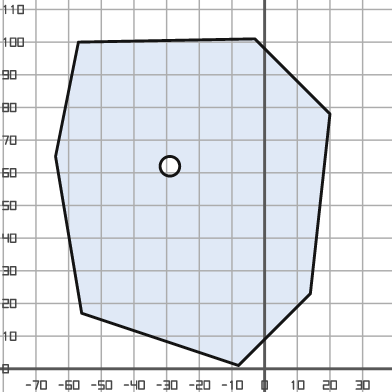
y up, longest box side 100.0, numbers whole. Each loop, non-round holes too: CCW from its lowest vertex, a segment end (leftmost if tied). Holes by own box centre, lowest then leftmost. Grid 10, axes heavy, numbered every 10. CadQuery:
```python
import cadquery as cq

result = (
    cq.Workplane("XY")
    .moveTo(-8.0, 1.0)
    .lineTo(14.0, 23.0)
    .lineTo(20.0, 78.0)
    .lineTo(-3.0, 101.0)
    .lineTo(-57.0, 100.0)
    .lineTo(-64.0, 65.0)
    .lineTo(-56.0, 17.0)
    .close()
    .moveTo(-29.0, 62.0)
    .circle(3.0)
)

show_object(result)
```